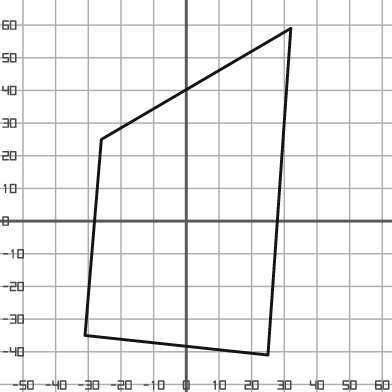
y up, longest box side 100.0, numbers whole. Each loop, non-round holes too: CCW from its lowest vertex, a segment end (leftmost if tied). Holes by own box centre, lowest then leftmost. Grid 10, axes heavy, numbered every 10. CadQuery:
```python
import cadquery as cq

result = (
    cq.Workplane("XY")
    .moveTo(25.0, -41.0)
    .lineTo(32.0, 59.0)
    .lineTo(-26.0, 25.0)
    .lineTo(-31.0, -35.0)
    .close()
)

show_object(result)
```